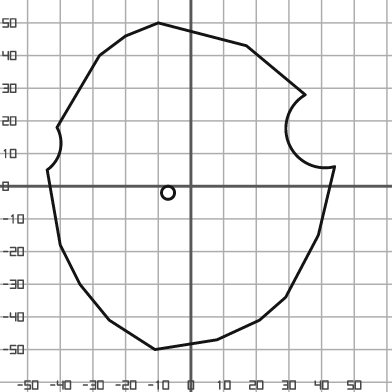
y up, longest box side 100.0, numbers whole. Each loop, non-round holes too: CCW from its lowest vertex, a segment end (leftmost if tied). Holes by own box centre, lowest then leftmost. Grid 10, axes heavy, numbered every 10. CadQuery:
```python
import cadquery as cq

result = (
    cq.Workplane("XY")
    .moveTo(-11.0, -50.0)
    .lineTo(8.0, -47.0)
    .lineTo(21.0, -41.0)
    .lineTo(29.0, -34.0)
    .lineTo(39.0, -15.0)
    .lineTo(44.0, 6.0)
    .threePointArc((30.0, 13.0), (35.0, 28.0))
    .lineTo(17.0, 43.0)
    .lineTo(-10.0, 50.0)
    .lineTo(-20.0, 46.0)
    .lineTo(-28.0, 40.0)
    .lineTo(-41.0, 18.0)
    .threePointArc((-40.0, 11.0), (-44.0, 5.0))
    .lineTo(-40.0, -18.0)
    .lineTo(-34.0, -30.0)
    .lineTo(-25.0, -41.0)
    .close()
    .moveTo(-7.0, -2.0)
    .circle(2.0)
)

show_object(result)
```